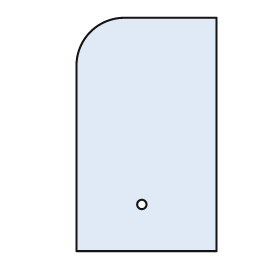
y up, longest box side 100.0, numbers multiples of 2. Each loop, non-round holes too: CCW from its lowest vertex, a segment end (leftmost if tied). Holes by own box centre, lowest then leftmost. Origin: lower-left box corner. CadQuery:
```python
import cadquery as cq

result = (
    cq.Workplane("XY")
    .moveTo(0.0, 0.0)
    .lineTo(60.0, 0.0)
    .lineTo(60.0, 100.0)
    .lineTo(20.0, 100.0)
    .threePointArc((6.0, 94.0), (0.0, 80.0))
    .close()
    .moveTo(28.0, 20.0)
    .circle(2.0)
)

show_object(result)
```